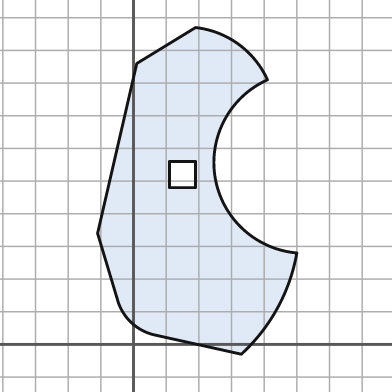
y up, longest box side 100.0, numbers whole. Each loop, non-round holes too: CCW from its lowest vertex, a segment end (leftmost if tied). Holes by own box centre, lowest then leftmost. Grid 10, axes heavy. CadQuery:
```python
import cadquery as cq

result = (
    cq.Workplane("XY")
    .moveTo(33.0, -3.0)
    .threePointArc((44.0, 11.0), (50.0, 28.0))
    .threePointArc((25.0, 51.0), (41.0, 81.0))
    .threePointArc((32.0, 92.0), (19.0, 97.0))
    .lineTo(1.0, 86.0)
    .lineTo(-11.0, 34.0)
    .lineTo(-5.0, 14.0)
    .threePointArc((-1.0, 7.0), (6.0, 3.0))
    .close()
    .moveTo(11.0, 48.0)
    .lineTo(19.0, 48.0)
    .lineTo(19.0, 56.0)
    .lineTo(11.0, 56.0)
    .close()
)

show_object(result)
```